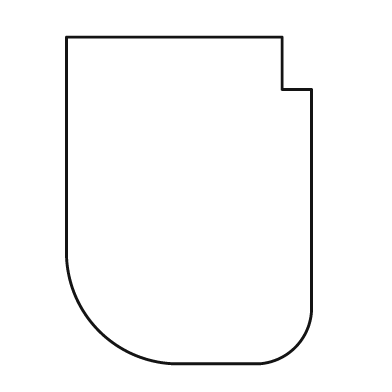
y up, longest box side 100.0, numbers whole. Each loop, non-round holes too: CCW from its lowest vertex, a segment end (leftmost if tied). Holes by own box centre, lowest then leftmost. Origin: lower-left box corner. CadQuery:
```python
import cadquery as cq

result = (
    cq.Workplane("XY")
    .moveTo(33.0, 0.0)
    .lineTo(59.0, 0.0)
    .threePointArc((70.0, 5.0), (75.0, 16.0))
    .lineTo(75.0, 84.0)
    .lineTo(66.0, 84.0)
    .lineTo(66.0, 100.0)
    .lineTo(0.0, 100.0)
    .lineTo(0.0, 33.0)
    .threePointArc((10.0, 10.0), (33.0, 0.0))
    .close()
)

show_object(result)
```